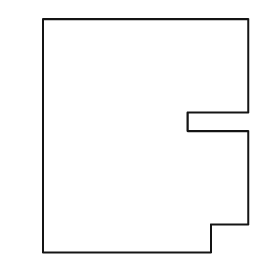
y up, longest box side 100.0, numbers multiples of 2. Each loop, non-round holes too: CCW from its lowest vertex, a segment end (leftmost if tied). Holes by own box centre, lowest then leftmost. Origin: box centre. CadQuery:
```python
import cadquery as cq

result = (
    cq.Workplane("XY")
    .moveTo(-44.0, -50.0)
    .lineTo(28.0, -50.0)
    .lineTo(28.0, -38.0)
    .lineTo(44.0, -38.0)
    .lineTo(44.0, 2.0)
    .lineTo(18.0, 2.0)
    .lineTo(18.0, 10.0)
    .lineTo(44.0, 10.0)
    .lineTo(44.0, 50.0)
    .lineTo(-44.0, 50.0)
    .close()
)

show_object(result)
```